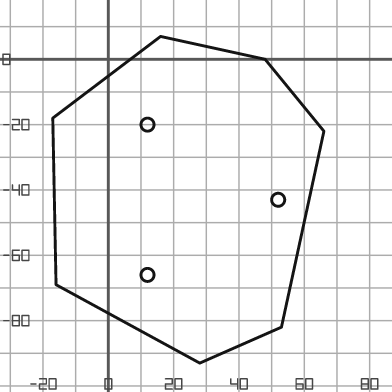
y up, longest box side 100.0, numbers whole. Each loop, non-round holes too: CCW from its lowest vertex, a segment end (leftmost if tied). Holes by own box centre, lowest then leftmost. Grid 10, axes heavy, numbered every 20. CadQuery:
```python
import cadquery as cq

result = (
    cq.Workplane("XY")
    .moveTo(28.0, -93.0)
    .lineTo(53.0, -82.0)
    .lineTo(66.0, -22.0)
    .lineTo(48.0, 0.0)
    .lineTo(16.0, 7.0)
    .lineTo(-17.0, -18.0)
    .lineTo(-16.0, -69.0)
    .close()
    .moveTo(12.0, -66.0)
    .circle(2.0)
    .moveTo(52.0, -43.0)
    .circle(2.0)
    .moveTo(12.0, -20.0)
    .circle(2.0)
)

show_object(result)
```